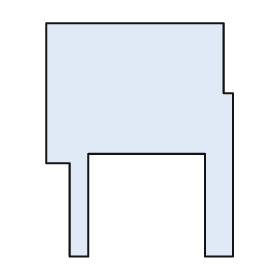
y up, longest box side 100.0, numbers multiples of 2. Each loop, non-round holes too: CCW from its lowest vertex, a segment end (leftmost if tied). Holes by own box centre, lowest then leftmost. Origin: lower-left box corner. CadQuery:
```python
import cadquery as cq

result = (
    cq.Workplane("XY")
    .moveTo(10.0, 0.0)
    .lineTo(18.0, 0.0)
    .lineTo(18.0, 44.0)
    .lineTo(68.0, 44.0)
    .lineTo(68.0, 0.0)
    .lineTo(80.0, 0.0)
    .lineTo(80.0, 70.0)
    .lineTo(76.0, 70.0)
    .lineTo(76.0, 100.0)
    .lineTo(0.0, 100.0)
    .lineTo(0.0, 40.0)
    .lineTo(10.0, 40.0)
    .close()
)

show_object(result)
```